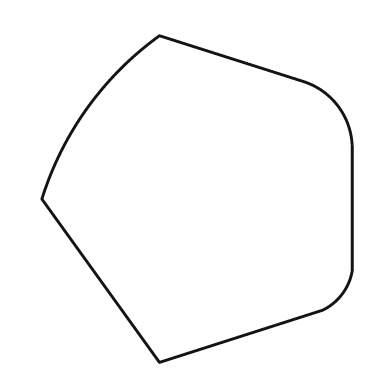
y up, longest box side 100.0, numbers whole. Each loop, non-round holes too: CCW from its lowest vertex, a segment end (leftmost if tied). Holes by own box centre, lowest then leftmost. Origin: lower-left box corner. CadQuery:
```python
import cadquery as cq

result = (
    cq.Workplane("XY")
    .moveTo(36.0, 0.0)
    .lineTo(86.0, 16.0)
    .threePointArc((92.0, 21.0), (95.0, 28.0))
    .lineTo(95.0, 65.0)
    .threePointArc((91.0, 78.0), (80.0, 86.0))
    .lineTo(36.0, 100.0)
    .threePointArc((14.0, 78.0), (0.0, 50.0))
    .close()
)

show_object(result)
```